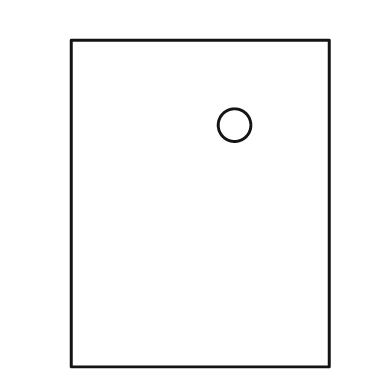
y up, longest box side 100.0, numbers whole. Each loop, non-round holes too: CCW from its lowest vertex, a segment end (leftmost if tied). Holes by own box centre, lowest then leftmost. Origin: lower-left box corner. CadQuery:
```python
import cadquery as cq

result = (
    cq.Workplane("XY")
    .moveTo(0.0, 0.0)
    .lineTo(79.0, 0.0)
    .lineTo(79.0, 100.0)
    .lineTo(0.0, 100.0)
    .close()
    .moveTo(50.0, 74.0)
    .circle(5.0)
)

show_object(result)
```